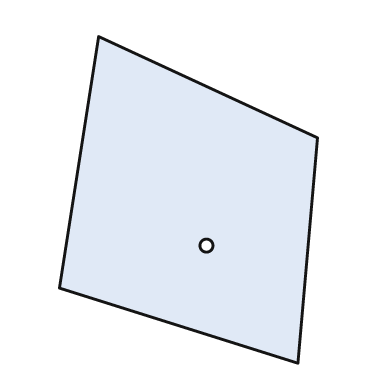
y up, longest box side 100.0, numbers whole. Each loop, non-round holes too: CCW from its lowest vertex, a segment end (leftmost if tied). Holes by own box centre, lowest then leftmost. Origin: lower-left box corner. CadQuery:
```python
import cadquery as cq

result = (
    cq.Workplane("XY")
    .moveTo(73.0, 0.0)
    .lineTo(79.0, 69.0)
    .lineTo(12.0, 100.0)
    .lineTo(0.0, 23.0)
    .close()
    .moveTo(45.0, 36.0)
    .circle(2.0)
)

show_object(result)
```